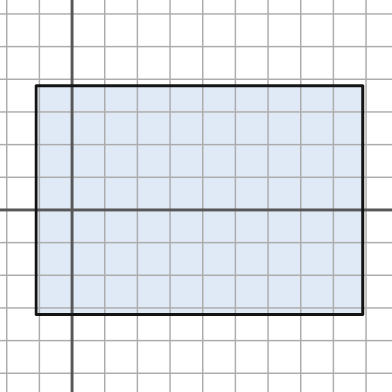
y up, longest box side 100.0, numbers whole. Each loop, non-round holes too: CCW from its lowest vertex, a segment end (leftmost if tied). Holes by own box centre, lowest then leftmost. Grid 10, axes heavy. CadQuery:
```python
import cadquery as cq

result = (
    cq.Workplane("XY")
    .moveTo(-11.0, -32.0)
    .lineTo(89.0, -32.0)
    .lineTo(89.0, 38.0)
    .lineTo(-11.0, 38.0)
    .close()
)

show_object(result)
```